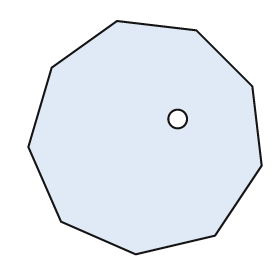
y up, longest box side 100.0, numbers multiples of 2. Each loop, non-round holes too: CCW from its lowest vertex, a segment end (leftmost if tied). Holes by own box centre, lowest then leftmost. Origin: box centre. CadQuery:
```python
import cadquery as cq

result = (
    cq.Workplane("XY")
    .moveTo(-4.0, -50.0)
    .lineTo(30.0, -42.0)
    .lineTo(50.0, -12.0)
    .lineTo(46.0, 22.0)
    .lineTo(22.0, 46.0)
    .lineTo(-12.0, 50.0)
    .lineTo(-40.0, 30.0)
    .lineTo(-50.0, -4.0)
    .lineTo(-36.0, -36.0)
    .close()
    .moveTo(14.0, 8.0)
    .circle(4.0)
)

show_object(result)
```